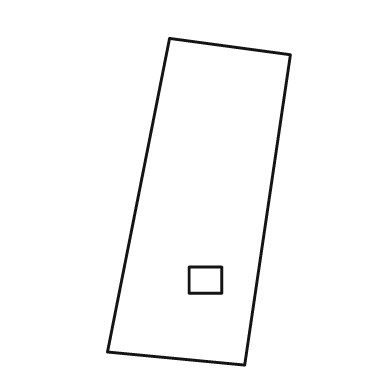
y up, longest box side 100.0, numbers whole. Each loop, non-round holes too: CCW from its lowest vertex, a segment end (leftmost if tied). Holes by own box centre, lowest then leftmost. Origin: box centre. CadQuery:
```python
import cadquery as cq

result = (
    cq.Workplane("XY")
    .moveTo(14.0, -50.0)
    .lineTo(28.0, 45.0)
    .lineTo(-9.0, 50.0)
    .lineTo(-28.0, -46.0)
    .close()
    .moveTo(-3.0, -28.0)
    .lineTo(7.0, -28.0)
    .lineTo(7.0, -20.0)
    .lineTo(-3.0, -20.0)
    .close()
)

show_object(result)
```